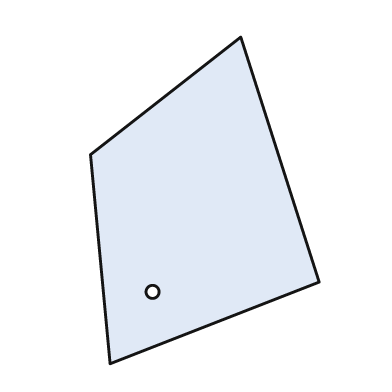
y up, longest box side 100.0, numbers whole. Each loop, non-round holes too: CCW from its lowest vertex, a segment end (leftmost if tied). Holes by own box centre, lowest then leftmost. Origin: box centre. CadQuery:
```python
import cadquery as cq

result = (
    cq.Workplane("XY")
    .moveTo(-29.0, -50.0)
    .lineTo(35.0, -25.0)
    .lineTo(11.0, 50.0)
    .lineTo(-35.0, 14.0)
    .close()
    .moveTo(-16.0, -28.0)
    .circle(2.0)
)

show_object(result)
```